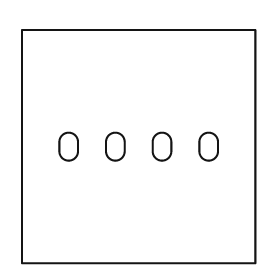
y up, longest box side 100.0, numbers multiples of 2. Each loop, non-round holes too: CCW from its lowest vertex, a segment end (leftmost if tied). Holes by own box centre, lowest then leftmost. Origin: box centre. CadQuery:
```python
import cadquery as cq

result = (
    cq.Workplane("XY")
    .moveTo(-50.0, -50.0)
    .lineTo(50.0, -50.0)
    .lineTo(50.0, 50.0)
    .lineTo(-50.0, 50.0)
    .close()
    .moveTo(-34.0, -2.0)
    .threePointArc((-30.0, -6.0), (-26.0, -2.0))
    .lineTo(-26.0, 2.0)
    .threePointArc((-30.0, 6.0), (-34.0, 2.0))
    .close()
    .moveTo(-14.0, -2.0)
    .threePointArc((-10.0, -6.0), (-6.0, -2.0))
    .lineTo(-6.0, 2.0)
    .threePointArc((-10.0, 6.0), (-14.0, 2.0))
    .close()
    .moveTo(6.0, -2.0)
    .threePointArc((10.0, -6.0), (14.0, -2.0))
    .lineTo(14.0, 2.0)
    .threePointArc((10.0, 6.0), (6.0, 2.0))
    .close()
    .moveTo(26.0, -2.0)
    .threePointArc((30.0, -6.0), (34.0, -2.0))
    .lineTo(34.0, 2.0)
    .threePointArc((30.0, 6.0), (26.0, 2.0))
    .close()
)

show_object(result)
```